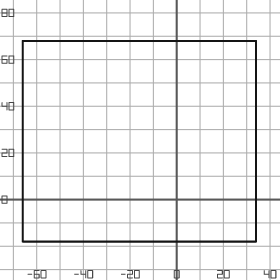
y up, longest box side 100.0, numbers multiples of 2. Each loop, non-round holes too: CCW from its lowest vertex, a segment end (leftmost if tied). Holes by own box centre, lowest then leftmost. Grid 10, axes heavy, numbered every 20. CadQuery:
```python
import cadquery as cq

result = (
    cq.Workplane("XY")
    .moveTo(-66.0, -18.0)
    .lineTo(34.0, -18.0)
    .lineTo(34.0, 68.0)
    .lineTo(-66.0, 68.0)
    .close()
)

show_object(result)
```